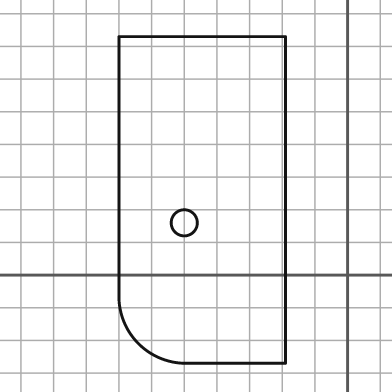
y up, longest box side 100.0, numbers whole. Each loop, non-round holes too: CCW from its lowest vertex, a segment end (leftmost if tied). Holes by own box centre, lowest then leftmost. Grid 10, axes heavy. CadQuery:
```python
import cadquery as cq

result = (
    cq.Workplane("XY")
    .moveTo(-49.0, -27.0)
    .lineTo(-19.0, -27.0)
    .lineTo(-19.0, 73.0)
    .lineTo(-70.0, 73.0)
    .lineTo(-70.0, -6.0)
    .threePointArc((-64.0, -21.0), (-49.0, -27.0))
    .close()
    .moveTo(-50.0, 16.0)
    .circle(4.0)
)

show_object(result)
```